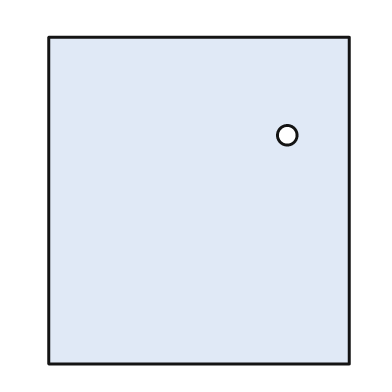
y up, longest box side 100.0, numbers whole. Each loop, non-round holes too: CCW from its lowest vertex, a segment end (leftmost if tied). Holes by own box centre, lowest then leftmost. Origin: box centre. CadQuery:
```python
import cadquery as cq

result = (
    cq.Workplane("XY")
    .moveTo(-46.0, -50.0)
    .lineTo(46.0, -50.0)
    .lineTo(46.0, 50.0)
    .lineTo(-46.0, 50.0)
    .close()
    .moveTo(27.0, 20.0)
    .circle(3.0)
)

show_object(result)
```